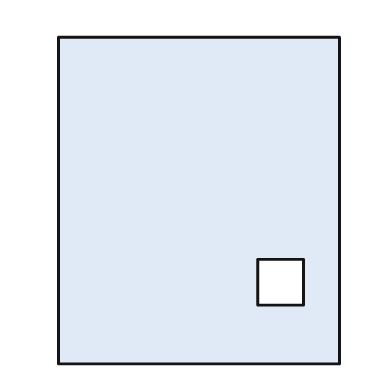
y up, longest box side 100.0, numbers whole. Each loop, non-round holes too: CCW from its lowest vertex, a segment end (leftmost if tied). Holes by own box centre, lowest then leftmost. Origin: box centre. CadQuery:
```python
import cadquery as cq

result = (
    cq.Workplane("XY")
    .moveTo(-43.0, -50.0)
    .lineTo(43.0, -50.0)
    .lineTo(43.0, 50.0)
    .lineTo(-43.0, 50.0)
    .close()
    .moveTo(18.0, -32.0)
    .lineTo(32.0, -32.0)
    .lineTo(32.0, -18.0)
    .lineTo(18.0, -18.0)
    .close()
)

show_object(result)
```